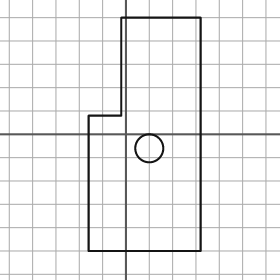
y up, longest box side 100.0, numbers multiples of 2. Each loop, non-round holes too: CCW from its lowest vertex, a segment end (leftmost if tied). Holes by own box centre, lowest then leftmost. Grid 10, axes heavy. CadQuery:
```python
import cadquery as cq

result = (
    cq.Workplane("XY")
    .moveTo(-16.0, -50.0)
    .lineTo(32.0, -50.0)
    .lineTo(32.0, 50.0)
    .lineTo(-2.0, 50.0)
    .lineTo(-2.0, 8.0)
    .lineTo(-16.0, 8.0)
    .close()
    .moveTo(10.0, -6.0)
    .circle(6.0)
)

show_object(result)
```